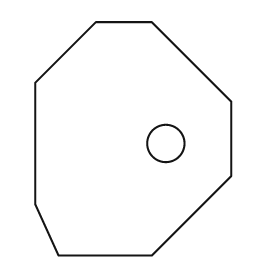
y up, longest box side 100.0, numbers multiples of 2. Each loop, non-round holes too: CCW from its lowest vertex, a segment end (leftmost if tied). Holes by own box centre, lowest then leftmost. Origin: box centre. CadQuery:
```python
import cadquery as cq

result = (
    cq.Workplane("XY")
    .moveTo(-32.0, -50.0)
    .lineTo(8.0, -50.0)
    .lineTo(42.0, -16.0)
    .lineTo(42.0, 16.0)
    .lineTo(8.0, 50.0)
    .lineTo(-16.0, 50.0)
    .lineTo(-42.0, 24.0)
    .lineTo(-42.0, -28.0)
    .close()
    .moveTo(14.0, -2.0)
    .circle(8.0)
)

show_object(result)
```